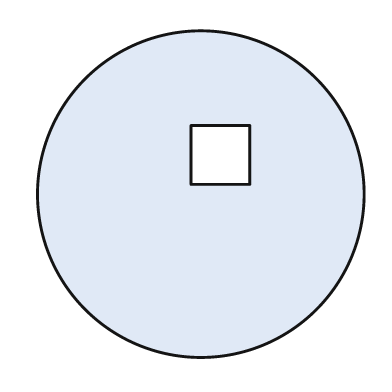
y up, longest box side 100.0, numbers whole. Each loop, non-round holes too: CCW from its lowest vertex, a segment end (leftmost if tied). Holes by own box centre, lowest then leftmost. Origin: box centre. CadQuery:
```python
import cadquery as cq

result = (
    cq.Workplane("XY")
    .moveTo(0.0, 0.0)
    .circle(50.0)
    .moveTo(-3.0, 3.0)
    .lineTo(15.0, 3.0)
    .lineTo(15.0, 21.0)
    .lineTo(-3.0, 21.0)
    .close()
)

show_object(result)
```